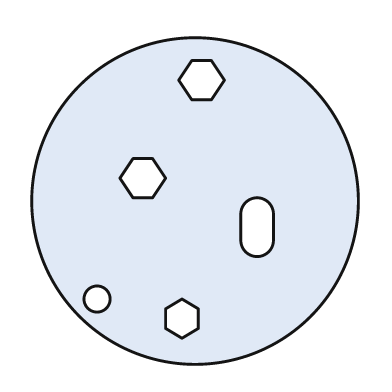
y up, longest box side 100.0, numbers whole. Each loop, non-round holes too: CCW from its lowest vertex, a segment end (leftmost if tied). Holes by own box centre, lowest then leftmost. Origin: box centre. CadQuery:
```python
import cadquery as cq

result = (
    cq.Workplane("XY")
    .moveTo(0.0, 0.0)
    .circle(50.0)
    .moveTo(-4.0, -42.0)
    .lineTo(1.0, -39.0)
    .lineTo(1.0, -33.0)
    .lineTo(-4.0, -30.0)
    .lineTo(-9.0, -33.0)
    .lineTo(-9.0, -39.0)
    .close()
    .moveTo(-30.0, -30.0)
    .circle(4.0)
    .moveTo(14.0, -12.0)
    .threePointArc((19.0, -17.0), (24.0, -12.0))
    .lineTo(24.0, -4.0)
    .threePointArc((19.0, 1.0), (14.0, -4.0))
    .close()
    .moveTo(-19.0, 1.0)
    .lineTo(-13.0, 1.0)
    .lineTo(-9.0, 7.0)
    .lineTo(-13.0, 13.0)
    .lineTo(-19.0, 13.0)
    .lineTo(-23.0, 7.0)
    .close()
    .moveTo(-1.0, 31.0)
    .lineTo(5.0, 31.0)
    .lineTo(9.0, 37.0)
    .lineTo(5.0, 43.0)
    .lineTo(-1.0, 43.0)
    .lineTo(-5.0, 37.0)
    .close()
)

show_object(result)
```